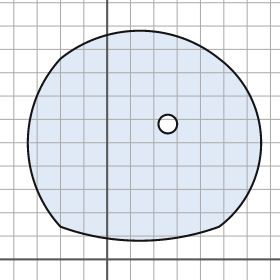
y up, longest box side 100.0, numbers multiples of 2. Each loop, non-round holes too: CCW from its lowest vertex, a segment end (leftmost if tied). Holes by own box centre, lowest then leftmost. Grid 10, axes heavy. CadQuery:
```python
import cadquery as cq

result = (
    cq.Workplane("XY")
    .moveTo(-20.0, 14.0)
    .threePointArc((14.0, 8.0), (48.0, 14.0))
    .threePointArc((66.0, 50.0), (48.0, 86.0))
    .threePointArc((14.0, 98.0), (-20.0, 86.0))
    .threePointArc((-34.0, 50.0), (-20.0, 14.0))
    .close()
    .moveTo(26.0, 58.0)
    .circle(4.0)
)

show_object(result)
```